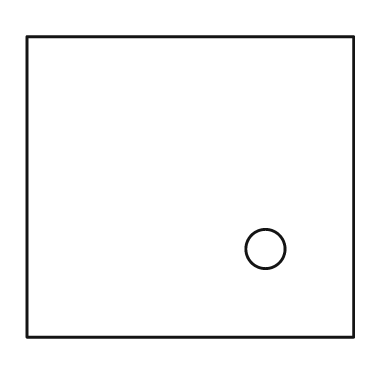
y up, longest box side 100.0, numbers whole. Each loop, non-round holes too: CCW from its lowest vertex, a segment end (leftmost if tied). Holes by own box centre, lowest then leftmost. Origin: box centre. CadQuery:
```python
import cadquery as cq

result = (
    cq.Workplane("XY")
    .moveTo(-50.0, -46.0)
    .lineTo(50.0, -46.0)
    .lineTo(50.0, 46.0)
    .lineTo(-50.0, 46.0)
    .close()
    .moveTo(23.0, -19.0)
    .circle(6.0)
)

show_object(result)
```